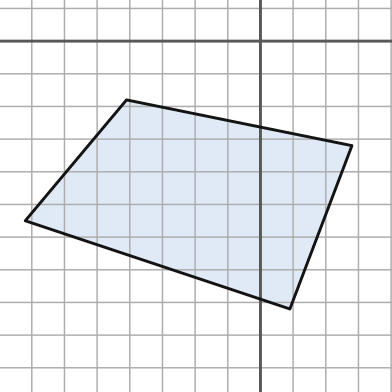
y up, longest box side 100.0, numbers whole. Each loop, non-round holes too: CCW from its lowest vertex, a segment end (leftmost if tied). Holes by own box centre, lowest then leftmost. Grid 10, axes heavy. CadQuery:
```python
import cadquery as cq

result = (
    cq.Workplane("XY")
    .moveTo(9.0, -82.0)
    .lineTo(28.0, -32.0)
    .lineTo(-41.0, -18.0)
    .lineTo(-72.0, -55.0)
    .close()
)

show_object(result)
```